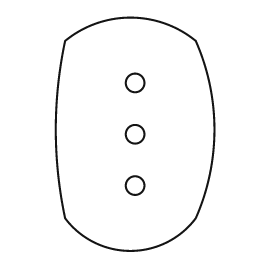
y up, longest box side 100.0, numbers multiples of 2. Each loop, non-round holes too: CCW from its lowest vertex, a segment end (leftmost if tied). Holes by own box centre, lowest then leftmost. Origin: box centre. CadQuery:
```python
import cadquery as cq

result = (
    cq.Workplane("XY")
    .moveTo(-30.0, -36.0)
    .threePointArc((-2.0, -50.0), (26.0, -36.0))
    .threePointArc((34.0, 2.0), (26.0, 40.0))
    .threePointArc((-2.0, 50.0), (-30.0, 40.0))
    .threePointArc((-34.0, 2.0), (-30.0, -36.0))
    .close()
    .moveTo(0.0, -22.0)
    .circle(4.0)
    .moveTo(0.0, 0.0)
    .circle(4.0)
    .moveTo(0.0, 22.0)
    .circle(4.0)
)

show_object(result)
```